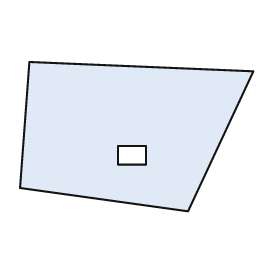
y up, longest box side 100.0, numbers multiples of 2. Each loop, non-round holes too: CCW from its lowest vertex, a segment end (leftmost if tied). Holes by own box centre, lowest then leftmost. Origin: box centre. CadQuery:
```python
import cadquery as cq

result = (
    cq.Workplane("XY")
    .moveTo(22.0, -32.0)
    .lineTo(50.0, 28.0)
    .lineTo(-46.0, 32.0)
    .lineTo(-50.0, -22.0)
    .close()
    .moveTo(-8.0, -12.0)
    .lineTo(4.0, -12.0)
    .lineTo(4.0, -4.0)
    .lineTo(-8.0, -4.0)
    .close()
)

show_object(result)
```